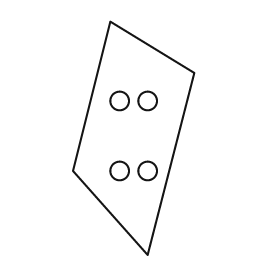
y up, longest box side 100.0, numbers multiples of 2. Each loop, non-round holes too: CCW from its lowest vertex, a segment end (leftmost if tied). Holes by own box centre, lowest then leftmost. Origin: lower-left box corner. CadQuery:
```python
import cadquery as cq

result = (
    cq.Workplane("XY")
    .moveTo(32.0, 0.0)
    .lineTo(52.0, 78.0)
    .lineTo(16.0, 100.0)
    .lineTo(0.0, 36.0)
    .close()
    .moveTo(20.0, 36.0)
    .circle(4.0)
    .moveTo(32.0, 36.0)
    .circle(4.0)
    .moveTo(20.0, 66.0)
    .circle(4.0)
    .moveTo(32.0, 66.0)
    .circle(4.0)
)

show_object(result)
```